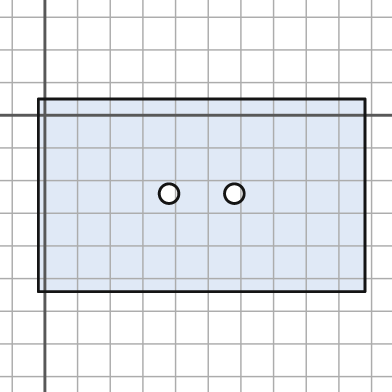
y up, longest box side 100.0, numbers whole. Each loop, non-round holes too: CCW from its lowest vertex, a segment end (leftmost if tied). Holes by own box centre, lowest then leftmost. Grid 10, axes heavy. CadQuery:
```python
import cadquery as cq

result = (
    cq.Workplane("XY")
    .moveTo(-2.0, -54.0)
    .lineTo(98.0, -54.0)
    .lineTo(98.0, 5.0)
    .lineTo(-2.0, 5.0)
    .close()
    .moveTo(38.0, -24.0)
    .circle(3.0)
    .moveTo(58.0, -24.0)
    .circle(3.0)
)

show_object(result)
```